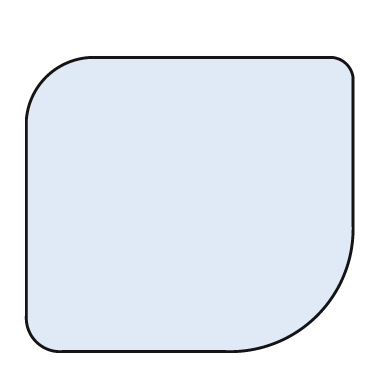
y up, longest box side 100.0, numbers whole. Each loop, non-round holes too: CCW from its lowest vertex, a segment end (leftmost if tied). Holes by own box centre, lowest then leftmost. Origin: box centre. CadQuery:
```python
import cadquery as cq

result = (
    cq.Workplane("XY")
    .moveTo(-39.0, -45.0)
    .lineTo(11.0, -45.0)
    .threePointArc((39.0, -34.0), (50.0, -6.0))
    .lineTo(50.0, 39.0)
    .threePointArc((48.0, 43.0), (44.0, 45.0))
    .lineTo(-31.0, 45.0)
    .threePointArc((-44.0, 39.0), (-50.0, 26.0))
    .lineTo(-50.0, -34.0)
    .threePointArc((-47.0, -42.0), (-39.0, -45.0))
    .close()
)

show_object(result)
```